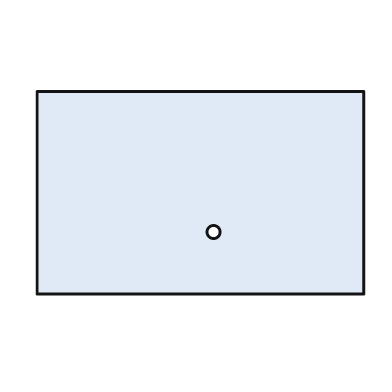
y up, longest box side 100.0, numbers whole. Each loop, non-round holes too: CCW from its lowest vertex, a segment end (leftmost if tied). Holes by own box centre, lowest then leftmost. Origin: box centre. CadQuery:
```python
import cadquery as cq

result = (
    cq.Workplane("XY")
    .moveTo(-50.0, -31.0)
    .lineTo(50.0, -31.0)
    .lineTo(50.0, 31.0)
    .lineTo(-50.0, 31.0)
    .close()
    .moveTo(4.0, -12.0)
    .circle(2.0)
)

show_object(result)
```